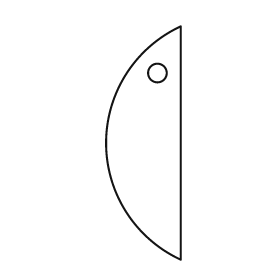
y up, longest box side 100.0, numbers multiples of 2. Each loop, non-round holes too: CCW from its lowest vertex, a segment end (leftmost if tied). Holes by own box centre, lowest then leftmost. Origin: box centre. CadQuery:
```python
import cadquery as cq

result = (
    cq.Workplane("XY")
    .moveTo(16.0, -50.0)
    .lineTo(16.0, 50.0)
    .threePointArc((-16.0, 0.0), (16.0, -50.0))
    .close()
    .moveTo(6.0, 30.0)
    .circle(4.0)
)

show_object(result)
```